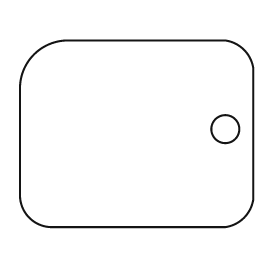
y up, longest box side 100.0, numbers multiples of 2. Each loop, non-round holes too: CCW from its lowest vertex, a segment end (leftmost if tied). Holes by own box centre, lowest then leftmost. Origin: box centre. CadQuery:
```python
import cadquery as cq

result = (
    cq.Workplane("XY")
    .moveTo(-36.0, -40.0)
    .lineTo(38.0, -40.0)
    .threePointArc((46.0, -36.0), (50.0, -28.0))
    .lineTo(50.0, 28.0)
    .threePointArc((46.0, 36.0), (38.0, 40.0))
    .lineTo(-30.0, 40.0)
    .threePointArc((-44.0, 34.0), (-50.0, 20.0))
    .lineTo(-50.0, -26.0)
    .threePointArc((-46.0, -36.0), (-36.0, -40.0))
    .close()
    .moveTo(38.0, 2.0)
    .circle(6.0)
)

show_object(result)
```